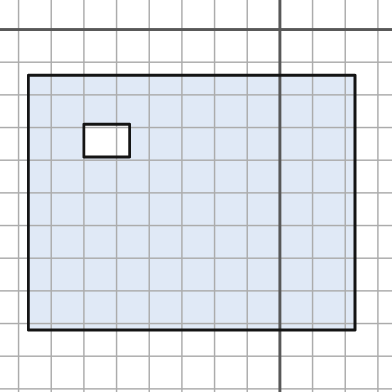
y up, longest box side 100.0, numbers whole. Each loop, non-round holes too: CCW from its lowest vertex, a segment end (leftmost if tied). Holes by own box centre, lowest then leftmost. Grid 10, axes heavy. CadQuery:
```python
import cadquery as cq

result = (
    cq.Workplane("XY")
    .moveTo(-77.0, -92.0)
    .lineTo(23.0, -92.0)
    .lineTo(23.0, -14.0)
    .lineTo(-77.0, -14.0)
    .close()
    .moveTo(-60.0, -39.0)
    .lineTo(-46.0, -39.0)
    .lineTo(-46.0, -29.0)
    .lineTo(-60.0, -29.0)
    .close()
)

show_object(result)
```